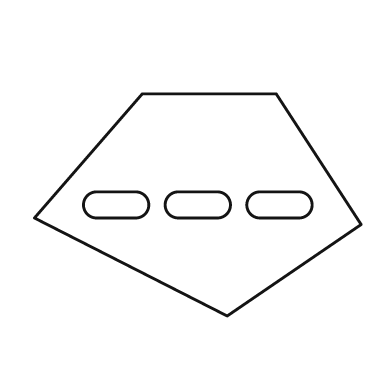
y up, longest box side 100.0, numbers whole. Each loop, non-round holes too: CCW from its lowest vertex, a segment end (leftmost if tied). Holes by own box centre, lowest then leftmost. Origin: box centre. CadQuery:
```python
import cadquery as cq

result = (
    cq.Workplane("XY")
    .moveTo(9.0, -34.0)
    .lineTo(50.0, -6.0)
    .lineTo(24.0, 34.0)
    .lineTo(-17.0, 34.0)
    .lineTo(-50.0, -4.0)
    .close()
    .moveTo(-31.0, -4.0)
    .lineTo(-19.0, -4.0)
    .threePointArc((-15.0, 0.0), (-19.0, 4.0))
    .lineTo(-31.0, 4.0)
    .threePointArc((-35.0, 0.0), (-31.0, -4.0))
    .close()
    .moveTo(-6.0, -4.0)
    .lineTo(6.0, -4.0)
    .threePointArc((10.0, 0.0), (6.0, 4.0))
    .lineTo(-6.0, 4.0)
    .threePointArc((-10.0, 0.0), (-6.0, -4.0))
    .close()
    .moveTo(19.0, -4.0)
    .lineTo(31.0, -4.0)
    .threePointArc((35.0, 0.0), (31.0, 4.0))
    .lineTo(19.0, 4.0)
    .threePointArc((15.0, 0.0), (19.0, -4.0))
    .close()
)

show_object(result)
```